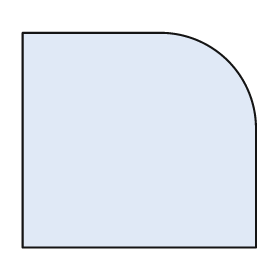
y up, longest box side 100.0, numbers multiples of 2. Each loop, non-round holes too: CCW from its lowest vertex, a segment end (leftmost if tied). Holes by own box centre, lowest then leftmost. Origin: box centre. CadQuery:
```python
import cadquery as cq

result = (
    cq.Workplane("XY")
    .moveTo(-50.0, -46.0)
    .lineTo(50.0, -46.0)
    .lineTo(50.0, 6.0)
    .threePointArc((38.0, 34.0), (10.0, 46.0))
    .lineTo(-50.0, 46.0)
    .close()
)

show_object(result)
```